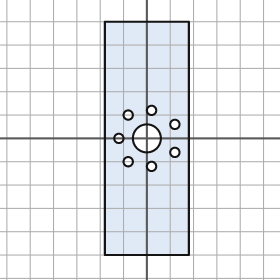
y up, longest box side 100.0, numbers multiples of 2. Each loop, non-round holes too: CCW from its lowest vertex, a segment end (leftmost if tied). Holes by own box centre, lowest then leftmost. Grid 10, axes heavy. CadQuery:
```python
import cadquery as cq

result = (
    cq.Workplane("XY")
    .moveTo(-18.0, -50.0)
    .lineTo(18.0, -50.0)
    .lineTo(18.0, 50.0)
    .lineTo(-18.0, 50.0)
    .close()
    .moveTo(2.0, -12.0)
    .circle(2.0)
    .moveTo(-8.0, -10.0)
    .circle(2.0)
    .moveTo(12.0, -6.0)
    .circle(2.0)
    .moveTo(-12.0, 0.0)
    .circle(2.0)
    .moveTo(0.0, 0.0)
    .circle(6.0)
    .moveTo(12.0, 6.0)
    .circle(2.0)
    .moveTo(-8.0, 10.0)
    .circle(2.0)
    .moveTo(2.0, 12.0)
    .circle(2.0)
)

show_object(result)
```